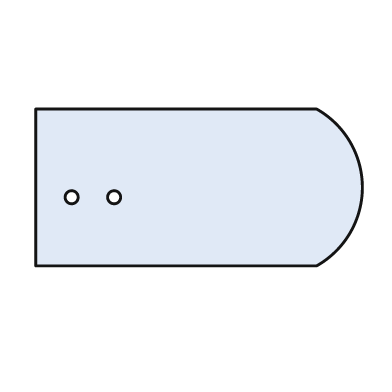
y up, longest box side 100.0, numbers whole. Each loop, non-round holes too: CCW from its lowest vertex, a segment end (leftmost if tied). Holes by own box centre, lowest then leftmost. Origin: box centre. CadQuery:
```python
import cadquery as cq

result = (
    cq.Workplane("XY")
    .moveTo(-50.0, -24.0)
    .lineTo(36.0, -24.0)
    .threePointArc((50.0, 0.0), (36.0, 24.0))
    .lineTo(-50.0, 24.0)
    .close()
    .moveTo(-39.0, -3.0)
    .circle(2.0)
    .moveTo(-26.0, -3.0)
    .circle(2.0)
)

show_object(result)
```